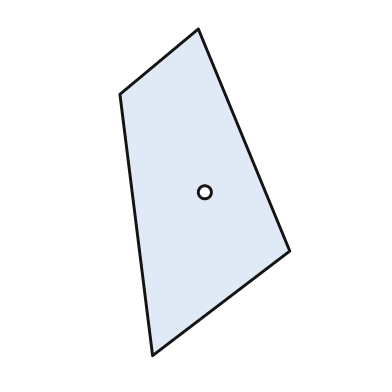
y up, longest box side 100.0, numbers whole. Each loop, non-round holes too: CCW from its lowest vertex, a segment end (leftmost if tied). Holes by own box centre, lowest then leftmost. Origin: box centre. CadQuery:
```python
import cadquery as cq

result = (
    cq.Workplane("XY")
    .moveTo(-16.0, -50.0)
    .lineTo(26.0, -18.0)
    .lineTo(-2.0, 50.0)
    .lineTo(-26.0, 30.0)
    .close()
    .moveTo(0.0, 0.0)
    .circle(2.0)
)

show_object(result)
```